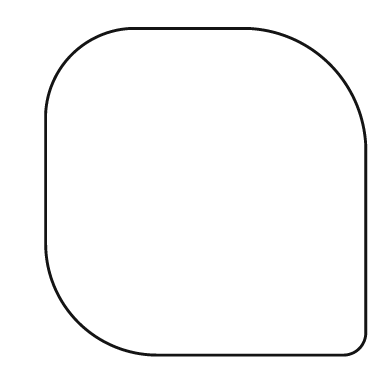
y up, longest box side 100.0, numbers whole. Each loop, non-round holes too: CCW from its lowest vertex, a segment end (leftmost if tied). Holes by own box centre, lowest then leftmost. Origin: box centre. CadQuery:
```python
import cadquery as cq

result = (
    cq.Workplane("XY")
    .moveTo(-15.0, -50.0)
    .lineTo(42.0, -50.0)
    .threePointArc((47.0, -48.0), (49.0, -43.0))
    .lineTo(49.0, 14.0)
    .threePointArc((38.0, 39.0), (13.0, 50.0))
    .lineTo(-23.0, 50.0)
    .threePointArc((-41.0, 42.0), (-49.0, 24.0))
    .lineTo(-49.0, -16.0)
    .threePointArc((-39.0, -40.0), (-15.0, -50.0))
    .close()
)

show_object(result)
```